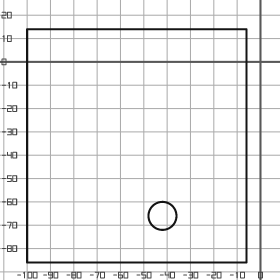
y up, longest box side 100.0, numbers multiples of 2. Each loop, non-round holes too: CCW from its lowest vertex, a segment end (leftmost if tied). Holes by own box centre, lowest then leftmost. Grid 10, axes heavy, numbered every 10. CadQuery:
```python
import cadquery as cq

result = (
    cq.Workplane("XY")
    .moveTo(-100.0, -86.0)
    .lineTo(-6.0, -86.0)
    .lineTo(-6.0, 14.0)
    .lineTo(-100.0, 14.0)
    .close()
    .moveTo(-42.0, -66.0)
    .circle(6.0)
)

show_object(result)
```